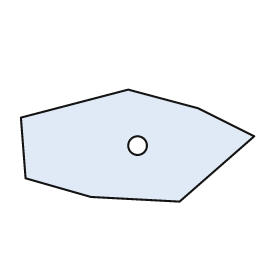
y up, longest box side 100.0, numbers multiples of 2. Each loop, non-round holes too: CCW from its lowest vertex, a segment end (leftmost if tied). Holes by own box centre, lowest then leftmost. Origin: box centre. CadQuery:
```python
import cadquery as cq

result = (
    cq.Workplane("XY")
    .moveTo(18.0, -24.0)
    .lineTo(50.0, 4.0)
    .lineTo(26.0, 16.0)
    .lineTo(-4.0, 24.0)
    .lineTo(-50.0, 12.0)
    .lineTo(-48.0, -14.0)
    .lineTo(-20.0, -22.0)
    .close()
    .moveTo(0.0, 0.0)
    .circle(4.0)
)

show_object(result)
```